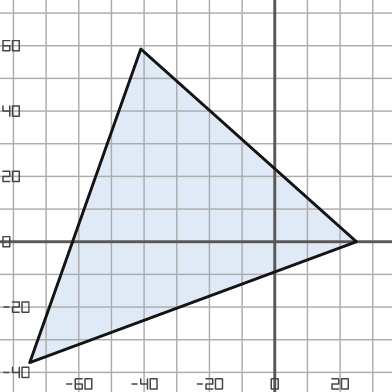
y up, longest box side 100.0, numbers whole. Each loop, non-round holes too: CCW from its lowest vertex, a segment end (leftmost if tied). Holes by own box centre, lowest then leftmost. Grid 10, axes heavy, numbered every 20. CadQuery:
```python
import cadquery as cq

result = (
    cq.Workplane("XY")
    .moveTo(-75.0, -37.0)
    .lineTo(25.0, 0.0)
    .lineTo(-41.0, 59.0)
    .close()
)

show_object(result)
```